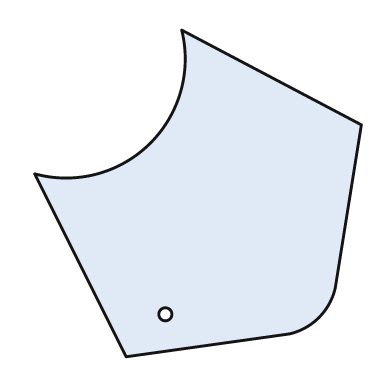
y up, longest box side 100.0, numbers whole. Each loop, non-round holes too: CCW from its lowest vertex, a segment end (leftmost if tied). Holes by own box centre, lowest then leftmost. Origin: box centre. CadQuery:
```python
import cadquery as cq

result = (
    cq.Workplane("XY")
    .moveTo(-22.0, -50.0)
    .lineTo(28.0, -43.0)
    .threePointArc((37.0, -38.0), (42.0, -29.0))
    .lineTo(50.0, 21.0)
    .lineTo(-5.0, 50.0)
    .threePointArc((-15.0, 15.0), (-50.0, 6.0))
    .close()
    .moveTo(-10.0, -37.0)
    .circle(2.0)
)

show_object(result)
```